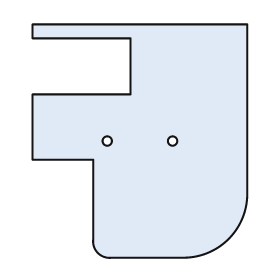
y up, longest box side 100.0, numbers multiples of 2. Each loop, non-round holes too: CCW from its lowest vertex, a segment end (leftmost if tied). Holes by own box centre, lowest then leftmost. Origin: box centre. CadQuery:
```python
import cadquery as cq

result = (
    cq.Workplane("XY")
    .moveTo(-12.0, -50.0)
    .lineTo(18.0, -50.0)
    .threePointArc((38.0, -42.0), (46.0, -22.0))
    .lineTo(46.0, 50.0)
    .lineTo(-46.0, 50.0)
    .lineTo(-46.0, 44.0)
    .lineTo(-4.0, 44.0)
    .lineTo(-4.0, 20.0)
    .lineTo(-46.0, 20.0)
    .lineTo(-46.0, -8.0)
    .lineTo(-20.0, -8.0)
    .lineTo(-20.0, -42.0)
    .threePointArc((-18.0, -48.0), (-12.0, -50.0))
    .close()
    .moveTo(-14.0, 0.0)
    .circle(2.0)
    .moveTo(14.0, 0.0)
    .circle(2.0)
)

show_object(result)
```